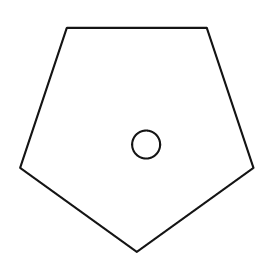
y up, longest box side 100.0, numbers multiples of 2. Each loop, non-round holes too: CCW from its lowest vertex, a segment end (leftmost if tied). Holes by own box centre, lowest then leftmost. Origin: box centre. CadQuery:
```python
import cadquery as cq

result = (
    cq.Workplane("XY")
    .moveTo(0.0, -48.0)
    .lineTo(50.0, -12.0)
    .lineTo(30.0, 48.0)
    .lineTo(-30.0, 48.0)
    .lineTo(-50.0, -12.0)
    .close()
    .moveTo(4.0, -2.0)
    .circle(6.0)
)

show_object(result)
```